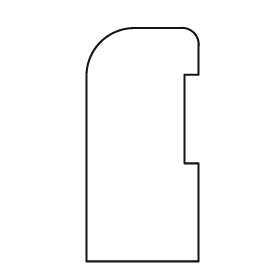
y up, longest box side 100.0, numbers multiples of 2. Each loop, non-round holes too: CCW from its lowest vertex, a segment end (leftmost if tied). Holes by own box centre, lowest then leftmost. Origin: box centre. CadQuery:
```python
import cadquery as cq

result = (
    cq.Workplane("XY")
    .moveTo(-24.0, -50.0)
    .lineTo(24.0, -50.0)
    .lineTo(24.0, -8.0)
    .lineTo(18.0, -8.0)
    .lineTo(18.0, 30.0)
    .lineTo(24.0, 30.0)
    .lineTo(24.0, 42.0)
    .threePointArc((22.0, 48.0), (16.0, 50.0))
    .lineTo(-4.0, 50.0)
    .threePointArc((-18.0, 44.0), (-24.0, 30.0))
    .close()
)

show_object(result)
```